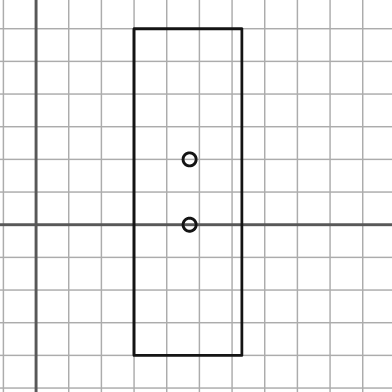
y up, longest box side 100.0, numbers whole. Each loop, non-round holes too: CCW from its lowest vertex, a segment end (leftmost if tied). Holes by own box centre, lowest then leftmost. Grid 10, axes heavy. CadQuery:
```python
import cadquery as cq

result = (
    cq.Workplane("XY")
    .moveTo(30.0, -40.0)
    .lineTo(63.0, -40.0)
    .lineTo(63.0, 60.0)
    .lineTo(30.0, 60.0)
    .close()
    .moveTo(47.0, 0.0)
    .circle(2.0)
    .moveTo(47.0, 20.0)
    .circle(2.0)
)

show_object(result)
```